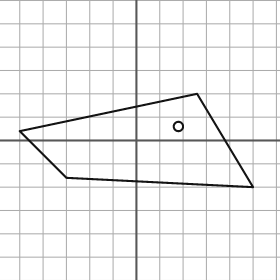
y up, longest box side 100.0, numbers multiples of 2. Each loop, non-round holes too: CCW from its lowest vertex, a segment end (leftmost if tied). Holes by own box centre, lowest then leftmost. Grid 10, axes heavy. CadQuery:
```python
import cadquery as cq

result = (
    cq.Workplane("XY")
    .moveTo(50.0, -20.0)
    .lineTo(26.0, 20.0)
    .lineTo(-50.0, 4.0)
    .lineTo(-30.0, -16.0)
    .close()
    .moveTo(18.0, 6.0)
    .circle(2.0)
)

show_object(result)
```